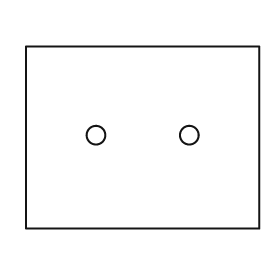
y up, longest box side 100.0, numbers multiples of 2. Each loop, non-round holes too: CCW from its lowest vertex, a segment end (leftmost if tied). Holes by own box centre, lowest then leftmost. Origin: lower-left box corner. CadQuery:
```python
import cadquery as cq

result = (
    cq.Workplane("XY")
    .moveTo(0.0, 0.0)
    .lineTo(100.0, 0.0)
    .lineTo(100.0, 78.0)
    .lineTo(0.0, 78.0)
    .close()
    .moveTo(30.0, 40.0)
    .circle(4.0)
    .moveTo(70.0, 40.0)
    .circle(4.0)
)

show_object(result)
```